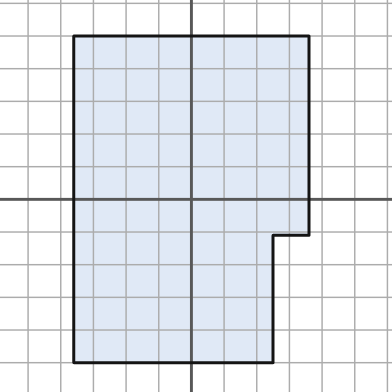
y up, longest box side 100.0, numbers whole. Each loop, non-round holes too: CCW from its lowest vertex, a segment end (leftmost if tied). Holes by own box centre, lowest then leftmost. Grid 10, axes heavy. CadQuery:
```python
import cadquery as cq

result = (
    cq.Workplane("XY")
    .moveTo(-36.0, -50.0)
    .lineTo(25.0, -50.0)
    .lineTo(25.0, -11.0)
    .lineTo(36.0, -11.0)
    .lineTo(36.0, 50.0)
    .lineTo(-36.0, 50.0)
    .close()
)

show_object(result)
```